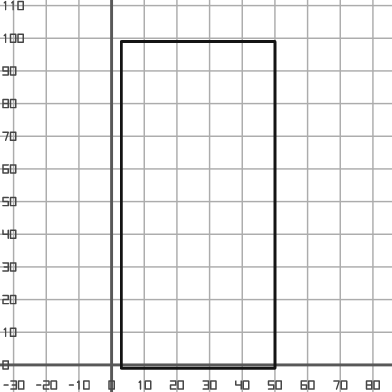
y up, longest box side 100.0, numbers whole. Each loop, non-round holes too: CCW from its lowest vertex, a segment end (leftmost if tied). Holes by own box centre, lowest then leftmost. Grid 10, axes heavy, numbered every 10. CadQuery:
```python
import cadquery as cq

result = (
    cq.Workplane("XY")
    .moveTo(3.0, -1.0)
    .lineTo(50.0, -1.0)
    .lineTo(50.0, 99.0)
    .lineTo(3.0, 99.0)
    .close()
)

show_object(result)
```